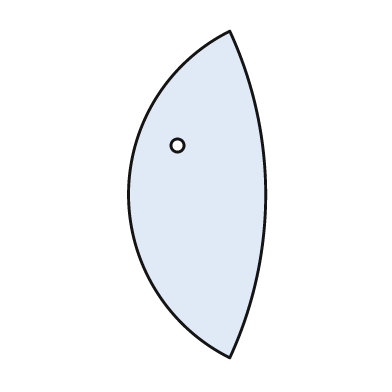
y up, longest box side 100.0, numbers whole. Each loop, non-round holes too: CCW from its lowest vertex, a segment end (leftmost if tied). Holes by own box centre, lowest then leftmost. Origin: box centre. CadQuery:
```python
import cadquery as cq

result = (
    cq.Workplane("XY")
    .moveTo(10.0, -50.0)
    .threePointArc((21.0, 0.0), (10.0, 50.0))
    .threePointArc((-21.0, 0.0), (10.0, -50.0))
    .close()
    .moveTo(-6.0, 15.0)
    .circle(2.0)
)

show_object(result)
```